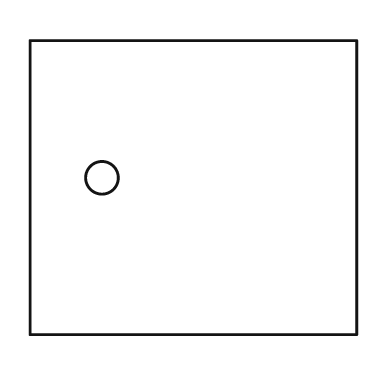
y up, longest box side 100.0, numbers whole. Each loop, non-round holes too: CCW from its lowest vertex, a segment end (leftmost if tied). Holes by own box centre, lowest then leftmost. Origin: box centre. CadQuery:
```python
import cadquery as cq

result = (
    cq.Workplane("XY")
    .moveTo(-50.0, -45.0)
    .lineTo(50.0, -45.0)
    .lineTo(50.0, 45.0)
    .lineTo(-50.0, 45.0)
    .close()
    .moveTo(-28.0, 3.0)
    .circle(5.0)
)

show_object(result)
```